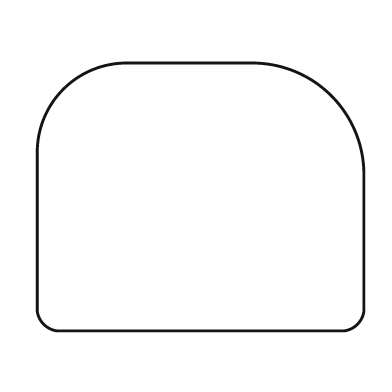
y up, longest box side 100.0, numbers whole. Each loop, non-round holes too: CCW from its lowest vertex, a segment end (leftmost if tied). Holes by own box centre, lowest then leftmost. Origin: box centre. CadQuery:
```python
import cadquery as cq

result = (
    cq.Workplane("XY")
    .moveTo(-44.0, -41.0)
    .lineTo(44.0, -41.0)
    .threePointArc((48.0, -39.0), (50.0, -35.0))
    .lineTo(50.0, 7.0)
    .threePointArc((40.0, 31.0), (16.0, 41.0))
    .lineTo(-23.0, 41.0)
    .threePointArc((-42.0, 33.0), (-50.0, 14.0))
    .lineTo(-50.0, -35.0)
    .threePointArc((-48.0, -39.0), (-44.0, -41.0))
    .close()
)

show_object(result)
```